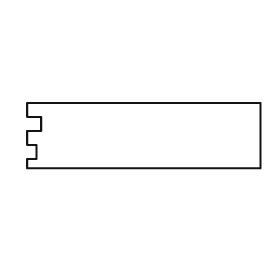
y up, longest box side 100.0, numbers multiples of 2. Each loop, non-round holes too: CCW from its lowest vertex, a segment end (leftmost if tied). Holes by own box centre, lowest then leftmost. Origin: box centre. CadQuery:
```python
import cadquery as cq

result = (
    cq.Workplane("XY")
    .moveTo(-50.0, -14.0)
    .lineTo(50.0, -14.0)
    .lineTo(50.0, 14.0)
    .lineTo(-50.0, 14.0)
    .lineTo(-50.0, 8.0)
    .lineTo(-44.0, 8.0)
    .lineTo(-44.0, 2.0)
    .lineTo(-50.0, 2.0)
    .lineTo(-50.0, -4.0)
    .lineTo(-46.0, -4.0)
    .lineTo(-46.0, -10.0)
    .lineTo(-50.0, -10.0)
    .close()
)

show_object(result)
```